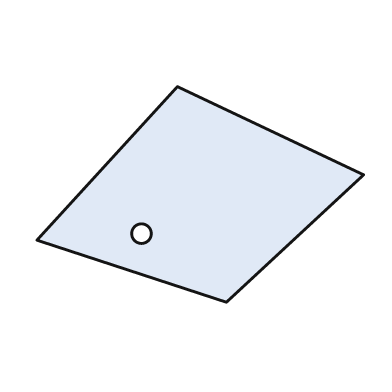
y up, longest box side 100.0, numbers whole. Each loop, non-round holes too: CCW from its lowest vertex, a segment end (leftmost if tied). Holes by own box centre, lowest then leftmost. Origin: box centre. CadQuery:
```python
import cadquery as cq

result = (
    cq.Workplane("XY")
    .moveTo(8.0, -33.0)
    .lineTo(50.0, 6.0)
    .lineTo(-7.0, 33.0)
    .lineTo(-50.0, -14.0)
    .close()
    .moveTo(-18.0, -12.0)
    .circle(3.0)
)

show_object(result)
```